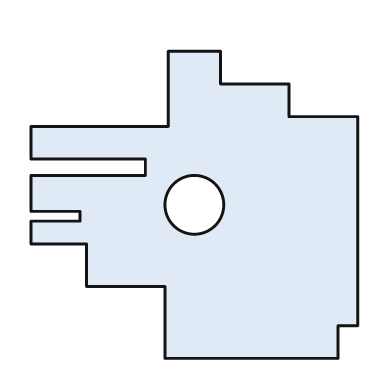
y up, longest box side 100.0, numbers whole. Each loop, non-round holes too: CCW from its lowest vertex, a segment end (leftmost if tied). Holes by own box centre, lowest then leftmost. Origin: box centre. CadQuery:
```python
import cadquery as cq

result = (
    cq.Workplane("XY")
    .moveTo(-9.0, -47.0)
    .lineTo(44.0, -47.0)
    .lineTo(44.0, -37.0)
    .lineTo(50.0, -37.0)
    .lineTo(50.0, 27.0)
    .lineTo(29.0, 27.0)
    .lineTo(29.0, 37.0)
    .lineTo(8.0, 37.0)
    .lineTo(8.0, 47.0)
    .lineTo(-8.0, 47.0)
    .lineTo(-8.0, 24.0)
    .lineTo(-50.0, 24.0)
    .lineTo(-50.0, 14.0)
    .lineTo(-15.0, 14.0)
    .lineTo(-15.0, 9.0)
    .lineTo(-50.0, 9.0)
    .lineTo(-50.0, -2.0)
    .lineTo(-35.0, -2.0)
    .lineTo(-35.0, -5.0)
    .lineTo(-50.0, -5.0)
    .lineTo(-50.0, -12.0)
    .lineTo(-33.0, -12.0)
    .lineTo(-33.0, -25.0)
    .lineTo(-9.0, -25.0)
    .close()
    .moveTo(0.0, 0.0)
    .circle(9.0)
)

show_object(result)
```